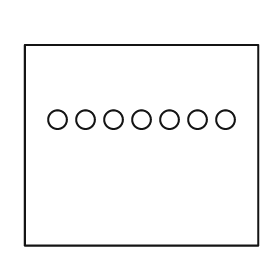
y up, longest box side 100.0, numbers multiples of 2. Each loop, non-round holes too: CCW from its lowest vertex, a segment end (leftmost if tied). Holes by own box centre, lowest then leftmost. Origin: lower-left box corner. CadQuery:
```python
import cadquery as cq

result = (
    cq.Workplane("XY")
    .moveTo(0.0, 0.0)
    .lineTo(100.0, 0.0)
    .lineTo(100.0, 86.0)
    .lineTo(0.0, 86.0)
    .close()
    .moveTo(14.0, 54.0)
    .circle(4.0)
    .moveTo(26.0, 54.0)
    .circle(4.0)
    .moveTo(38.0, 54.0)
    .circle(4.0)
    .moveTo(50.0, 54.0)
    .circle(4.0)
    .moveTo(62.0, 54.0)
    .circle(4.0)
    .moveTo(74.0, 54.0)
    .circle(4.0)
    .moveTo(86.0, 54.0)
    .circle(4.0)
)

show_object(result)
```